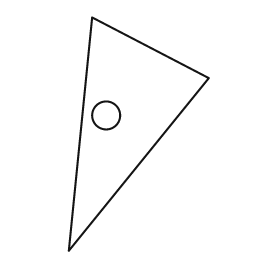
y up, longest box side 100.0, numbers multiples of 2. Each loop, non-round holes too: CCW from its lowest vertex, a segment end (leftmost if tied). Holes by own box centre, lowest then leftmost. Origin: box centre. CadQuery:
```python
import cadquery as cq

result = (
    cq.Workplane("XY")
    .moveTo(-30.0, -50.0)
    .lineTo(30.0, 24.0)
    .lineTo(-20.0, 50.0)
    .close()
    .moveTo(-14.0, 8.0)
    .circle(6.0)
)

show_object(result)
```